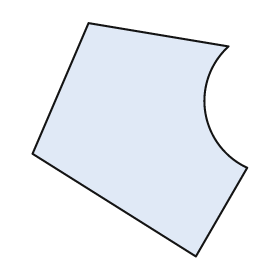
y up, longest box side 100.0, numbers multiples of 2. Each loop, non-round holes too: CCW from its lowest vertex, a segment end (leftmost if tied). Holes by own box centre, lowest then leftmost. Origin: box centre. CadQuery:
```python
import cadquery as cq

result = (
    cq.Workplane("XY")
    .moveTo(24.0, -50.0)
    .lineTo(46.0, -12.0)
    .threePointArc((28.0, 12.0), (38.0, 40.0))
    .lineTo(-22.0, 50.0)
    .lineTo(-46.0, -6.0)
    .close()
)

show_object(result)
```